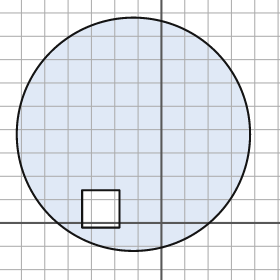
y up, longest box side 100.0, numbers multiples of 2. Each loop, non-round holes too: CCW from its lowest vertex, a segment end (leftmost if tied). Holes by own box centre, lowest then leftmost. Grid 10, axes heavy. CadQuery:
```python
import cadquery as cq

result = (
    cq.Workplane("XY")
    .moveTo(-12.0, 38.0)
    .circle(50.0)
    .moveTo(-34.0, -2.0)
    .lineTo(-18.0, -2.0)
    .lineTo(-18.0, 14.0)
    .lineTo(-34.0, 14.0)
    .close()
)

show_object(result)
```